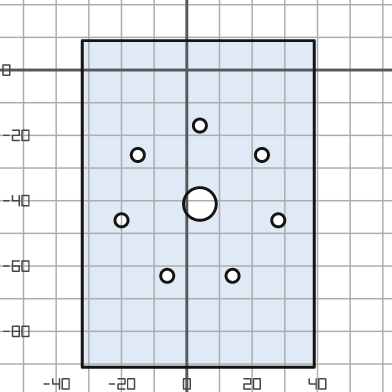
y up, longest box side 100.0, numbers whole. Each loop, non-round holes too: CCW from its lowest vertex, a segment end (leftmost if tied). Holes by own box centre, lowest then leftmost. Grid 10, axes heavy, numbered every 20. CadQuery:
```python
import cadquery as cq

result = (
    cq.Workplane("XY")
    .moveTo(-32.0, -91.0)
    .lineTo(39.0, -91.0)
    .lineTo(39.0, 9.0)
    .lineTo(-32.0, 9.0)
    .close()
    .moveTo(-6.0, -63.0)
    .circle(2.0)
    .moveTo(14.0, -63.0)
    .circle(2.0)
    .moveTo(-20.0, -46.0)
    .circle(2.0)
    .moveTo(28.0, -46.0)
    .circle(2.0)
    .moveTo(4.0, -41.0)
    .circle(5.0)
    .moveTo(-15.0, -26.0)
    .circle(2.0)
    .moveTo(23.0, -26.0)
    .circle(2.0)
    .moveTo(4.0, -17.0)
    .circle(2.0)
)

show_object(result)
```